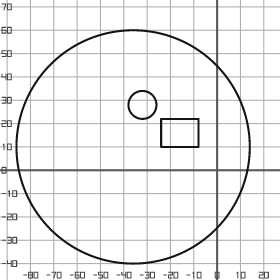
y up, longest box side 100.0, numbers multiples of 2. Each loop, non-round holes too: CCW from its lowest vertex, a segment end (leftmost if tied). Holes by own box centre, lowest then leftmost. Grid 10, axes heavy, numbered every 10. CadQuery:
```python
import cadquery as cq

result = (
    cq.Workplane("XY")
    .moveTo(-36.0, 10.0)
    .circle(50.0)
    .moveTo(-24.0, 10.0)
    .lineTo(-8.0, 10.0)
    .lineTo(-8.0, 22.0)
    .lineTo(-24.0, 22.0)
    .close()
    .moveTo(-32.0, 28.0)
    .circle(6.0)
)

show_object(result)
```